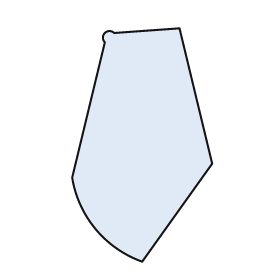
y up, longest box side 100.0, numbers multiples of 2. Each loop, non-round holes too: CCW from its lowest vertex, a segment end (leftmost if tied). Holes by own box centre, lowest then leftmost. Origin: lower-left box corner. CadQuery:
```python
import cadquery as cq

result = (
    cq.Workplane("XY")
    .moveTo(30.0, 0.0)
    .lineTo(60.0, 42.0)
    .lineTo(46.0, 100.0)
    .lineTo(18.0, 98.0)
    .threePointArc((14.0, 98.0), (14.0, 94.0))
    .lineTo(0.0, 36.0)
    .threePointArc((10.0, 14.0), (30.0, 0.0))
    .close()
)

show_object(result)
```